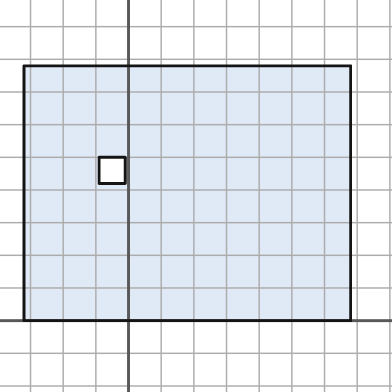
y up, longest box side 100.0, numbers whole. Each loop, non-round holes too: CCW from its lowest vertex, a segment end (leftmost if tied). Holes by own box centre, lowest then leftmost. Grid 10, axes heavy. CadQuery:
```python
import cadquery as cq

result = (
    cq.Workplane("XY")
    .moveTo(-32.0, 0.0)
    .lineTo(68.0, 0.0)
    .lineTo(68.0, 78.0)
    .lineTo(-32.0, 78.0)
    .close()
    .moveTo(-9.0, 42.0)
    .lineTo(-1.0, 42.0)
    .lineTo(-1.0, 50.0)
    .lineTo(-9.0, 50.0)
    .close()
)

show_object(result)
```